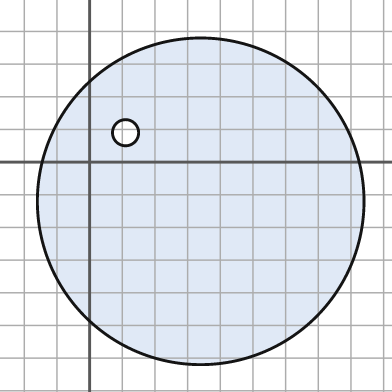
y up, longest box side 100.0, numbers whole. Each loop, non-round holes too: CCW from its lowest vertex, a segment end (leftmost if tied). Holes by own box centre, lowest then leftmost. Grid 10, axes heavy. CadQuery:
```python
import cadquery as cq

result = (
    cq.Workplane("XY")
    .moveTo(34.0, -12.0)
    .circle(50.0)
    .moveTo(11.0, 9.0)
    .circle(4.0)
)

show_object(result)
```